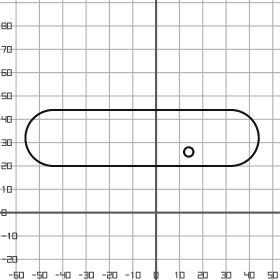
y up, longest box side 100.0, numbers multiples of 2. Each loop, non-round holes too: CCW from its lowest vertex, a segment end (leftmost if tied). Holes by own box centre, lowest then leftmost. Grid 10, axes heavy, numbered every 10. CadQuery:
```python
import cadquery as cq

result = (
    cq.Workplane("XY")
    .moveTo(-44.0, 20.0)
    .lineTo(32.0, 20.0)
    .threePointArc((44.0, 32.0), (32.0, 44.0))
    .lineTo(-44.0, 44.0)
    .threePointArc((-56.0, 32.0), (-44.0, 20.0))
    .close()
    .moveTo(14.0, 26.0)
    .circle(2.0)
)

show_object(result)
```